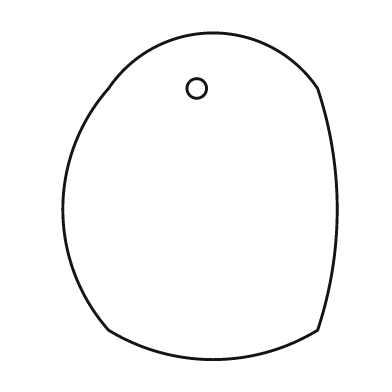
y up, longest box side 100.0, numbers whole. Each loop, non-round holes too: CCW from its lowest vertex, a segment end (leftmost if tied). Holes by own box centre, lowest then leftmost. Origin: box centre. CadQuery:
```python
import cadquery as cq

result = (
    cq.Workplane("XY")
    .moveTo(-28.0, -41.0)
    .threePointArc((4.0, -50.0), (36.0, -41.0))
    .threePointArc((42.0, -4.0), (36.0, 33.0))
    .threePointArc((4.0, 50.0), (-28.0, 33.0))
    .threePointArc((-42.0, -4.0), (-28.0, -41.0))
    .close()
    .moveTo(-1.0, 33.0)
    .circle(3.0)
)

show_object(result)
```